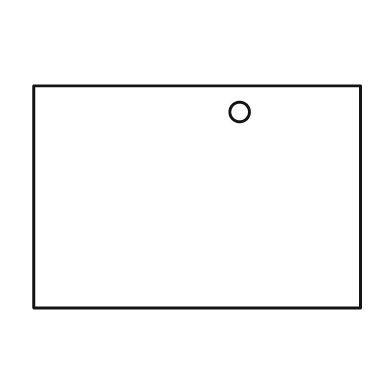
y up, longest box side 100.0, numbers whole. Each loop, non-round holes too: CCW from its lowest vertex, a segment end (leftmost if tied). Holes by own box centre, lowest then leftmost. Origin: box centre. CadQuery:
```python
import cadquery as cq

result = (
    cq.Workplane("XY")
    .moveTo(-50.0, -34.0)
    .lineTo(50.0, -34.0)
    .lineTo(50.0, 34.0)
    .lineTo(-50.0, 34.0)
    .close()
    .moveTo(13.0, 26.0)
    .circle(3.0)
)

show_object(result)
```